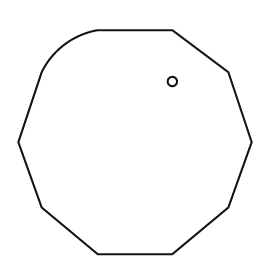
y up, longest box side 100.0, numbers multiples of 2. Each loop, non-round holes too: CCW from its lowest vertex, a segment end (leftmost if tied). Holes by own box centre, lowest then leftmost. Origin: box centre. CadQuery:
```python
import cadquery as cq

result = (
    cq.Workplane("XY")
    .moveTo(-16.0, -48.0)
    .lineTo(16.0, -48.0)
    .lineTo(40.0, -28.0)
    .lineTo(50.0, 0.0)
    .lineTo(40.0, 30.0)
    .lineTo(16.0, 48.0)
    .lineTo(-16.0, 48.0)
    .threePointArc((-30.0, 42.0), (-40.0, 30.0))
    .lineTo(-50.0, 0.0)
    .lineTo(-40.0, -28.0)
    .close()
    .moveTo(16.0, 26.0)
    .circle(2.0)
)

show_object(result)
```